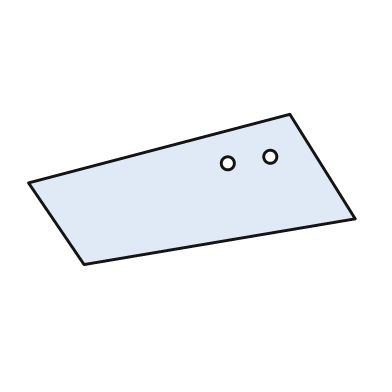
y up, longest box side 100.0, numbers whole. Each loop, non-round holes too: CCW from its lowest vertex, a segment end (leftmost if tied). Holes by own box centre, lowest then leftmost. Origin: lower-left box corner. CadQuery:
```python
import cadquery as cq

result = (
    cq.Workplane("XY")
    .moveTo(17.0, 0.0)
    .lineTo(100.0, 14.0)
    .lineTo(80.0, 46.0)
    .lineTo(0.0, 25.0)
    .close()
    .moveTo(61.0, 31.0)
    .circle(2.0)
    .moveTo(74.0, 33.0)
    .circle(2.0)
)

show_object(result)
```